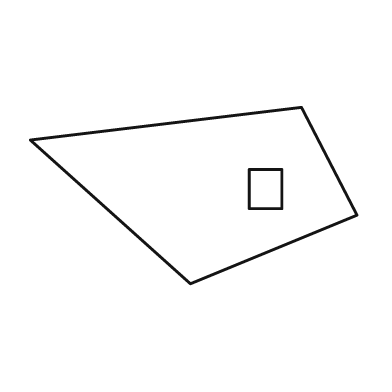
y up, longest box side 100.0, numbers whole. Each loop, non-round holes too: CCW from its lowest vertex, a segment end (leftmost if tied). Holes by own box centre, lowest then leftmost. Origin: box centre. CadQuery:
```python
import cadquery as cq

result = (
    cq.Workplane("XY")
    .moveTo(-1.0, -27.0)
    .lineTo(50.0, -6.0)
    .lineTo(33.0, 27.0)
    .lineTo(-50.0, 17.0)
    .close()
    .moveTo(17.0, -4.0)
    .lineTo(27.0, -4.0)
    .lineTo(27.0, 8.0)
    .lineTo(17.0, 8.0)
    .close()
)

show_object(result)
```